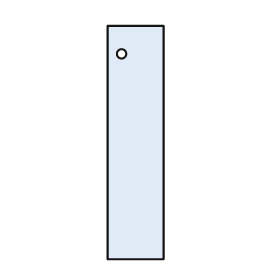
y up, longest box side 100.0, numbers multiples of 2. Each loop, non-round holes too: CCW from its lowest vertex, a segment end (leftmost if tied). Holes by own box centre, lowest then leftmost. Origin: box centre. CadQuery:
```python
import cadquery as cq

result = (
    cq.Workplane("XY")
    .moveTo(-12.0, -50.0)
    .lineTo(12.0, -50.0)
    .lineTo(12.0, 50.0)
    .lineTo(-12.0, 50.0)
    .close()
    .moveTo(-6.0, 38.0)
    .circle(2.0)
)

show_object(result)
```